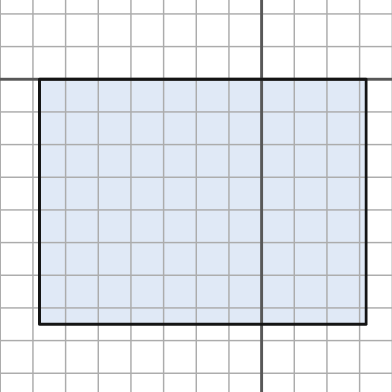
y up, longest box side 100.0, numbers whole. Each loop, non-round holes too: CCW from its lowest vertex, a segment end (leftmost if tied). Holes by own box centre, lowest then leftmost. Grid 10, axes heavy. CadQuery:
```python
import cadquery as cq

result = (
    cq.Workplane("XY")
    .moveTo(-68.0, -75.0)
    .lineTo(32.0, -75.0)
    .lineTo(32.0, 0.0)
    .lineTo(-68.0, 0.0)
    .close()
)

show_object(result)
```